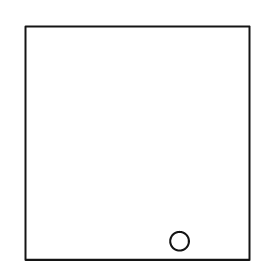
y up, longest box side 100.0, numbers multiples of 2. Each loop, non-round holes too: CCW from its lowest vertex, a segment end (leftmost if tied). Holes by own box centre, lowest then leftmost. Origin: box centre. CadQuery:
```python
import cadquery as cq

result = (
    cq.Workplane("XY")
    .moveTo(-48.0, -50.0)
    .lineTo(48.0, -50.0)
    .lineTo(48.0, 50.0)
    .lineTo(-48.0, 50.0)
    .close()
    .moveTo(18.0, -42.0)
    .circle(4.0)
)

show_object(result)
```